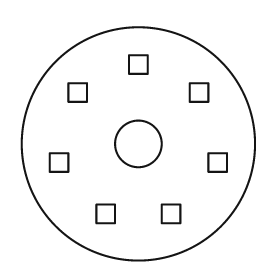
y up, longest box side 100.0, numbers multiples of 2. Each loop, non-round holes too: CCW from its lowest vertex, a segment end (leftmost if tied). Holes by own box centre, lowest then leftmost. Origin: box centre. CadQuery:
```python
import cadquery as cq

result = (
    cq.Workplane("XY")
    .moveTo(0.0, 0.0)
    .circle(50.0)
    .moveTo(-18.0, -34.0)
    .lineTo(-10.0, -34.0)
    .lineTo(-10.0, -26.0)
    .lineTo(-18.0, -26.0)
    .close()
    .moveTo(10.0, -34.0)
    .lineTo(18.0, -34.0)
    .lineTo(18.0, -26.0)
    .lineTo(10.0, -26.0)
    .close()
    .moveTo(-38.0, -12.0)
    .lineTo(-30.0, -12.0)
    .lineTo(-30.0, -4.0)
    .lineTo(-38.0, -4.0)
    .close()
    .moveTo(30.0, -12.0)
    .lineTo(38.0, -12.0)
    .lineTo(38.0, -4.0)
    .lineTo(30.0, -4.0)
    .close()
    .moveTo(0.0, 0.0)
    .circle(10.0)
    .moveTo(-30.0, 18.0)
    .lineTo(-22.0, 18.0)
    .lineTo(-22.0, 26.0)
    .lineTo(-30.0, 26.0)
    .close()
    .moveTo(22.0, 18.0)
    .lineTo(30.0, 18.0)
    .lineTo(30.0, 26.0)
    .lineTo(22.0, 26.0)
    .close()
    .moveTo(-4.0, 30.0)
    .lineTo(4.0, 30.0)
    .lineTo(4.0, 38.0)
    .lineTo(-4.0, 38.0)
    .close()
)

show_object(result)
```